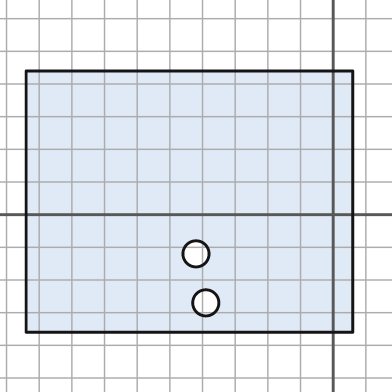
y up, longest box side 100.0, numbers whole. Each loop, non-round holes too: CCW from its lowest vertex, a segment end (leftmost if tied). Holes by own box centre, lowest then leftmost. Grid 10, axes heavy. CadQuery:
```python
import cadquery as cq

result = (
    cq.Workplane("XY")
    .moveTo(-94.0, -36.0)
    .lineTo(6.0, -36.0)
    .lineTo(6.0, 44.0)
    .lineTo(-94.0, 44.0)
    .close()
    .moveTo(-39.0, -27.0)
    .circle(4.0)
    .moveTo(-42.0, -12.0)
    .circle(4.0)
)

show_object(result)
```